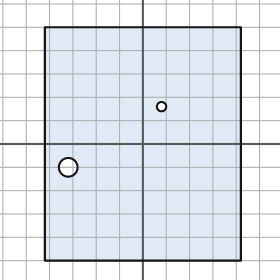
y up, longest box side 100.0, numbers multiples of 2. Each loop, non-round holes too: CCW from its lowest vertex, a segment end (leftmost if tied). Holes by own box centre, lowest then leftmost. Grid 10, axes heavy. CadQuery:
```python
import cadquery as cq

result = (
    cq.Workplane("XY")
    .moveTo(-42.0, -50.0)
    .lineTo(42.0, -50.0)
    .lineTo(42.0, 50.0)
    .lineTo(-42.0, 50.0)
    .close()
    .moveTo(-32.0, -10.0)
    .circle(4.0)
    .moveTo(8.0, 16.0)
    .circle(2.0)
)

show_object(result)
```